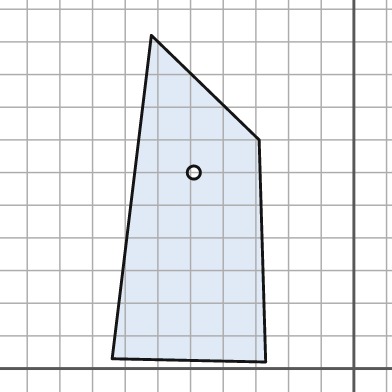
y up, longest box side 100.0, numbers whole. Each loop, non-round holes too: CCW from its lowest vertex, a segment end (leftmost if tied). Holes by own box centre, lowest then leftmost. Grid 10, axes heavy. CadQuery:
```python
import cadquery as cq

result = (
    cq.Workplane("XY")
    .moveTo(-27.0, 2.0)
    .lineTo(-29.0, 70.0)
    .lineTo(-62.0, 102.0)
    .lineTo(-74.0, 3.0)
    .close()
    .moveTo(-49.0, 60.0)
    .circle(2.0)
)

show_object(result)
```